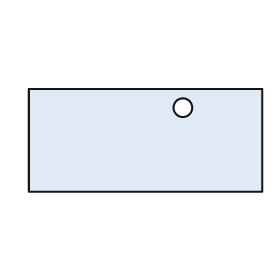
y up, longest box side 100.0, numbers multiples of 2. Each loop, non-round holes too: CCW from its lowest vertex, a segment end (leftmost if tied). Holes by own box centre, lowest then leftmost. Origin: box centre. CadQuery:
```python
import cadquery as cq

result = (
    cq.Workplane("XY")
    .moveTo(-50.0, -22.0)
    .lineTo(50.0, -22.0)
    .lineTo(50.0, 22.0)
    .lineTo(-50.0, 22.0)
    .close()
    .moveTo(16.0, 14.0)
    .circle(4.0)
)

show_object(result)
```